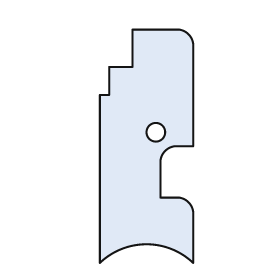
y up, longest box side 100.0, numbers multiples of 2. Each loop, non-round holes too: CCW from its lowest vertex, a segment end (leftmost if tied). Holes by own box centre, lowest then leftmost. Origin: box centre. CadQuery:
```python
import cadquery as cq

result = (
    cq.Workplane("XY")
    .moveTo(-20.0, -50.0)
    .threePointArc((0.0, -42.0), (20.0, -50.0))
    .lineTo(20.0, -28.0)
    .threePointArc((18.0, -24.0), (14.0, -22.0))
    .lineTo(6.0, -22.0)
    .lineTo(6.0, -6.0)
    .threePointArc((8.0, -2.0), (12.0, 0.0))
    .lineTo(20.0, 0.0)
    .lineTo(20.0, 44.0)
    .threePointArc((18.0, 48.0), (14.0, 50.0))
    .lineTo(-6.0, 50.0)
    .lineTo(-6.0, 34.0)
    .lineTo(-16.0, 34.0)
    .lineTo(-16.0, 22.0)
    .lineTo(-20.0, 22.0)
    .close()
    .moveTo(4.0, 6.0)
    .circle(4.0)
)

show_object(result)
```